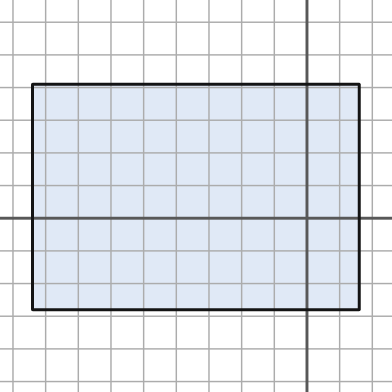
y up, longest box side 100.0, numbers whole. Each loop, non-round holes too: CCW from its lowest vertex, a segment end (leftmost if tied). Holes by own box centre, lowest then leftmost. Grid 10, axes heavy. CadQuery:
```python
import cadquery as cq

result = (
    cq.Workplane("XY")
    .moveTo(-84.0, -28.0)
    .lineTo(16.0, -28.0)
    .lineTo(16.0, 41.0)
    .lineTo(-84.0, 41.0)
    .close()
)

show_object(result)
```